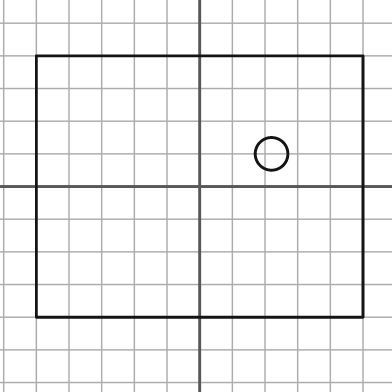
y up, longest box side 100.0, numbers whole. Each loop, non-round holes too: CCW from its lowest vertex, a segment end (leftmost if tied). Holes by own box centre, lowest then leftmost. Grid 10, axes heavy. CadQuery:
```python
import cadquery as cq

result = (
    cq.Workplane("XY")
    .moveTo(-50.0, -40.0)
    .lineTo(50.0, -40.0)
    .lineTo(50.0, 40.0)
    .lineTo(-50.0, 40.0)
    .close()
    .moveTo(22.0, 10.0)
    .circle(5.0)
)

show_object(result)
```